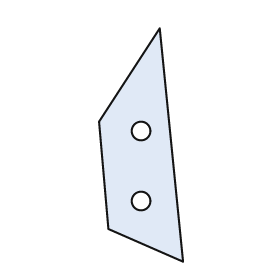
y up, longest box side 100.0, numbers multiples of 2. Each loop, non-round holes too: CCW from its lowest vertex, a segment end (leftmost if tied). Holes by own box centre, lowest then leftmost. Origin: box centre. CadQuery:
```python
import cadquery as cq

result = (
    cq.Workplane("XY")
    .moveTo(18.0, -50.0)
    .lineTo(8.0, 50.0)
    .lineTo(-18.0, 10.0)
    .lineTo(-14.0, -36.0)
    .close()
    .moveTo(0.0, -24.0)
    .circle(4.0)
    .moveTo(0.0, 6.0)
    .circle(4.0)
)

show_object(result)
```